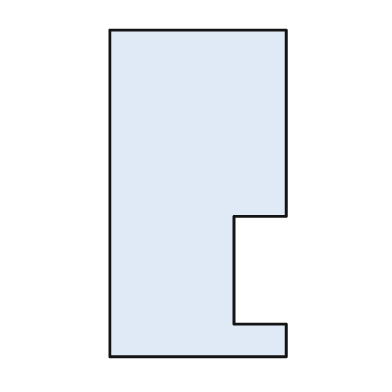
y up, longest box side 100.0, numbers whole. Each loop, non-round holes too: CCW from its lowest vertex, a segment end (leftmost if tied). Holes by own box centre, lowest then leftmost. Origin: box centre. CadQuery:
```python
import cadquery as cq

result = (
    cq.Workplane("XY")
    .moveTo(-27.0, -50.0)
    .lineTo(27.0, -50.0)
    .lineTo(27.0, -40.0)
    .lineTo(11.0, -40.0)
    .lineTo(11.0, -7.0)
    .lineTo(27.0, -7.0)
    .lineTo(27.0, 50.0)
    .lineTo(-27.0, 50.0)
    .close()
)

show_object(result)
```